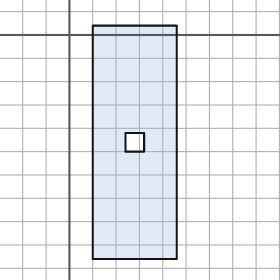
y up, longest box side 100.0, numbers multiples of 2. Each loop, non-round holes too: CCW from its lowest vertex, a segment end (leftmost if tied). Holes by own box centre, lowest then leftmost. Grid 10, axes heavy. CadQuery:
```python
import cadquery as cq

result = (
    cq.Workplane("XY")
    .moveTo(10.0, -96.0)
    .lineTo(46.0, -96.0)
    .lineTo(46.0, 4.0)
    .lineTo(10.0, 4.0)
    .close()
    .moveTo(24.0, -50.0)
    .lineTo(32.0, -50.0)
    .lineTo(32.0, -42.0)
    .lineTo(24.0, -42.0)
    .close()
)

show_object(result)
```